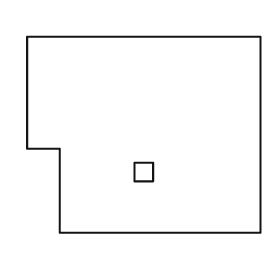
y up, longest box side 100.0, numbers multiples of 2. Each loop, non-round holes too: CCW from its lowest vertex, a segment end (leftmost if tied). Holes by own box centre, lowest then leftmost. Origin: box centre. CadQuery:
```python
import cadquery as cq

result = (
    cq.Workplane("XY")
    .moveTo(-36.0, -42.0)
    .lineTo(50.0, -42.0)
    .lineTo(50.0, 42.0)
    .lineTo(-50.0, 42.0)
    .lineTo(-50.0, -6.0)
    .lineTo(-36.0, -6.0)
    .close()
    .moveTo(-4.0, -20.0)
    .lineTo(4.0, -20.0)
    .lineTo(4.0, -12.0)
    .lineTo(-4.0, -12.0)
    .close()
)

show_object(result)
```